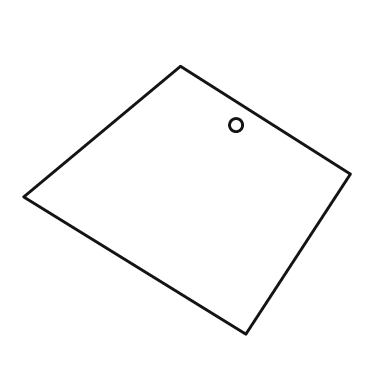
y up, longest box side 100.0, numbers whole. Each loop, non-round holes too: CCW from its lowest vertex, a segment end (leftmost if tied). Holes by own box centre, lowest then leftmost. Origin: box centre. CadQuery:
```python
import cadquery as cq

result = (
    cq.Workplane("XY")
    .moveTo(18.0, -41.0)
    .lineTo(50.0, 8.0)
    .lineTo(-2.0, 41.0)
    .lineTo(-50.0, 1.0)
    .close()
    .moveTo(15.0, 23.0)
    .circle(2.0)
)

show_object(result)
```